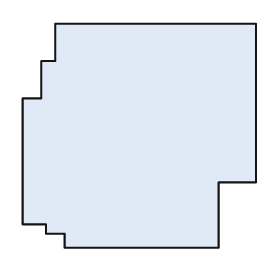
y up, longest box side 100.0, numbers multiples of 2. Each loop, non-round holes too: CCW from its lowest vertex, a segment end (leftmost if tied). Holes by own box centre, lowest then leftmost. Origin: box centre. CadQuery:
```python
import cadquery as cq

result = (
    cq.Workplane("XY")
    .moveTo(-32.0, -48.0)
    .lineTo(34.0, -48.0)
    .lineTo(34.0, -20.0)
    .lineTo(50.0, -20.0)
    .lineTo(50.0, 48.0)
    .lineTo(-36.0, 48.0)
    .lineTo(-36.0, 32.0)
    .lineTo(-42.0, 32.0)
    .lineTo(-42.0, 16.0)
    .lineTo(-50.0, 16.0)
    .lineTo(-50.0, -38.0)
    .lineTo(-40.0, -38.0)
    .lineTo(-40.0, -42.0)
    .lineTo(-32.0, -42.0)
    .close()
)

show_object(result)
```